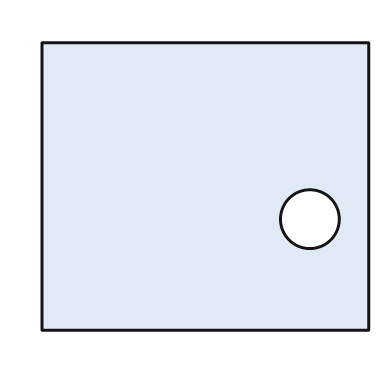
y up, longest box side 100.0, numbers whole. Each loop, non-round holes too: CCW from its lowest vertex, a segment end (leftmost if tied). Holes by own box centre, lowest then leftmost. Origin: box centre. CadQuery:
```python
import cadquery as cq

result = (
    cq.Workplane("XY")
    .moveTo(-50.0, -44.0)
    .lineTo(50.0, -44.0)
    .lineTo(50.0, 44.0)
    .lineTo(-50.0, 44.0)
    .close()
    .moveTo(32.0, -10.0)
    .circle(9.0)
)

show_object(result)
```